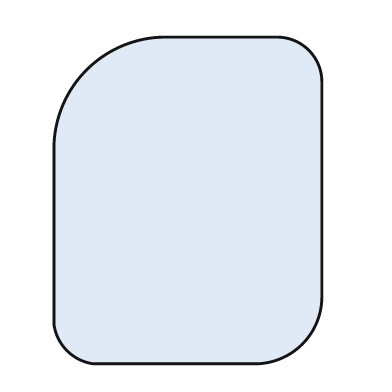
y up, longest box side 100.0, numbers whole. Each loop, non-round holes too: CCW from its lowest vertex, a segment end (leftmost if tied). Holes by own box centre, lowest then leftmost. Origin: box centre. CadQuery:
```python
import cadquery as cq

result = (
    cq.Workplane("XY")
    .moveTo(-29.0, -50.0)
    .lineTo(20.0, -50.0)
    .threePointArc((35.0, -44.0), (41.0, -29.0))
    .lineTo(41.0, 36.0)
    .threePointArc((37.0, 46.0), (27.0, 50.0))
    .lineTo(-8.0, 50.0)
    .threePointArc((-31.0, 40.0), (-41.0, 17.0))
    .lineTo(-41.0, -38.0)
    .threePointArc((-37.0, -46.0), (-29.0, -50.0))
    .close()
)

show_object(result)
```